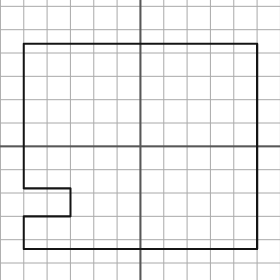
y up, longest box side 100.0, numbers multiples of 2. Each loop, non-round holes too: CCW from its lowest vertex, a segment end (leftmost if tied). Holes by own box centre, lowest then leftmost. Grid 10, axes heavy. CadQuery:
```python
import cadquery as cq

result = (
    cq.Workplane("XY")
    .moveTo(-50.0, -44.0)
    .lineTo(50.0, -44.0)
    .lineTo(50.0, 44.0)
    .lineTo(-50.0, 44.0)
    .lineTo(-50.0, -18.0)
    .lineTo(-30.0, -18.0)
    .lineTo(-30.0, -30.0)
    .lineTo(-50.0, -30.0)
    .close()
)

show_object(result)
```